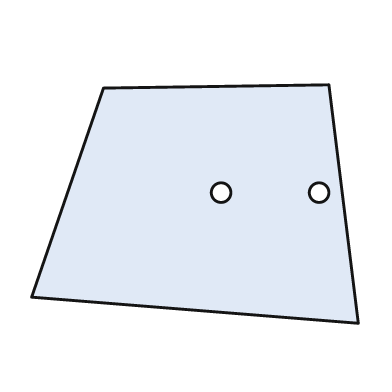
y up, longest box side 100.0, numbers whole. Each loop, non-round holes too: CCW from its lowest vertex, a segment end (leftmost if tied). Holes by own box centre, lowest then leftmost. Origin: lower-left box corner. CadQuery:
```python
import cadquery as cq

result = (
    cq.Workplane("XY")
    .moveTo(100.0, 0.0)
    .lineTo(91.0, 73.0)
    .lineTo(22.0, 72.0)
    .lineTo(0.0, 8.0)
    .close()
    .moveTo(58.0, 40.0)
    .circle(3.0)
    .moveTo(88.0, 40.0)
    .circle(3.0)
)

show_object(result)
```